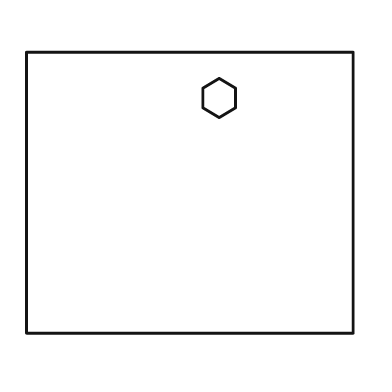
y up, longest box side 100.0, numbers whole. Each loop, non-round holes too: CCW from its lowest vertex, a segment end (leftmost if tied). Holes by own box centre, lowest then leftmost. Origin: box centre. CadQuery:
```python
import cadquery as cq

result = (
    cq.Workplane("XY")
    .moveTo(-50.0, -43.0)
    .lineTo(50.0, -43.0)
    .lineTo(50.0, 43.0)
    .lineTo(-50.0, 43.0)
    .close()
    .moveTo(9.0, 23.0)
    .lineTo(14.0, 26.0)
    .lineTo(14.0, 32.0)
    .lineTo(9.0, 35.0)
    .lineTo(4.0, 32.0)
    .lineTo(4.0, 26.0)
    .close()
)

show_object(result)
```